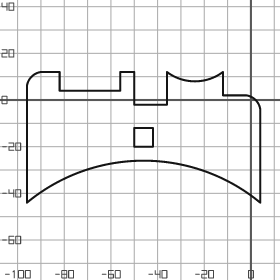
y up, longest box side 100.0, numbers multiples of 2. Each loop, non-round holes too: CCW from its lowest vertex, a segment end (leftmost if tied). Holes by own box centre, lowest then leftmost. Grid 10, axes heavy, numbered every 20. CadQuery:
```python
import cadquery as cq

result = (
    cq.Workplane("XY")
    .moveTo(-96.0, -44.0)
    .threePointArc((-46.0, -26.0), (4.0, -44.0))
    .lineTo(4.0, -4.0)
    .threePointArc((2.0, 0.0), (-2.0, 2.0))
    .lineTo(-12.0, 2.0)
    .lineTo(-12.0, 12.0)
    .threePointArc((-24.0, 8.0), (-36.0, 12.0))
    .lineTo(-36.0, -2.0)
    .lineTo(-50.0, -2.0)
    .lineTo(-50.0, 12.0)
    .lineTo(-56.0, 12.0)
    .lineTo(-56.0, 4.0)
    .lineTo(-82.0, 4.0)
    .lineTo(-82.0, 12.0)
    .lineTo(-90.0, 12.0)
    .threePointArc((-94.0, 10.0), (-96.0, 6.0))
    .close()
    .moveTo(-50.0, -20.0)
    .lineTo(-42.0, -20.0)
    .lineTo(-42.0, -12.0)
    .lineTo(-50.0, -12.0)
    .close()
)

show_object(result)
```